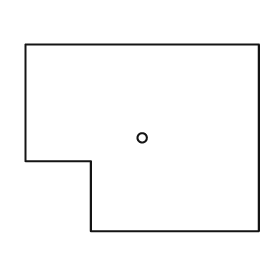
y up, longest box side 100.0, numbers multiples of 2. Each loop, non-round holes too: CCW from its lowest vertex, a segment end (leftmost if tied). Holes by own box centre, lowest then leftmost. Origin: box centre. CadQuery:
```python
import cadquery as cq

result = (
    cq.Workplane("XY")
    .moveTo(-22.0, -40.0)
    .lineTo(50.0, -40.0)
    .lineTo(50.0, 40.0)
    .lineTo(-50.0, 40.0)
    .lineTo(-50.0, -10.0)
    .lineTo(-22.0, -10.0)
    .close()
    .moveTo(0.0, 0.0)
    .circle(2.0)
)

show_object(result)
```